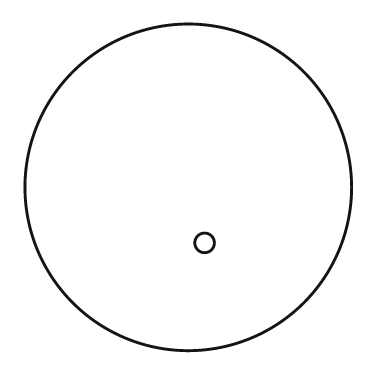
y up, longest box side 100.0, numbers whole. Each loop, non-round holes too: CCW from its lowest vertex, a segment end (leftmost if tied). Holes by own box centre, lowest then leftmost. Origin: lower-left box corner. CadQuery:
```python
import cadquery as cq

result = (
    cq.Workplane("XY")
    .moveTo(50.0, 50.0)
    .circle(50.0)
    .moveTo(55.0, 33.0)
    .circle(3.0)
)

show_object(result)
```